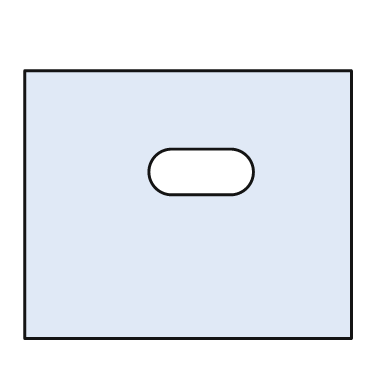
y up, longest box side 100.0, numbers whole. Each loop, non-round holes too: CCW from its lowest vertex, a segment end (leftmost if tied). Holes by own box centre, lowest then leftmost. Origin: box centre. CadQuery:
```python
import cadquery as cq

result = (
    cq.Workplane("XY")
    .moveTo(-50.0, -41.0)
    .lineTo(50.0, -41.0)
    .lineTo(50.0, 41.0)
    .lineTo(-50.0, 41.0)
    .close()
    .moveTo(-5.0, 3.0)
    .lineTo(13.0, 3.0)
    .threePointArc((20.0, 10.0), (13.0, 17.0))
    .lineTo(-5.0, 17.0)
    .threePointArc((-12.0, 10.0), (-5.0, 3.0))
    .close()
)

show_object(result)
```